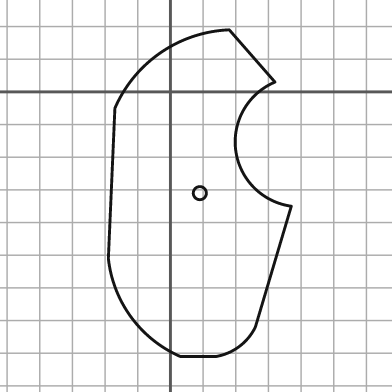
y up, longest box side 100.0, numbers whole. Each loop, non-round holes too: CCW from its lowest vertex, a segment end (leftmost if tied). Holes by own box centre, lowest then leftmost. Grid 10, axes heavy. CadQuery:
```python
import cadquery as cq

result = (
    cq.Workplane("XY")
    .moveTo(3.0, -81.0)
    .lineTo(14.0, -81.0)
    .threePointArc((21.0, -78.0), (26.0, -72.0))
    .lineTo(37.0, -35.0)
    .threePointArc((20.0, -18.0), (32.0, 3.0))
    .lineTo(18.0, 19.0)
    .threePointArc((-3.0, 12.0), (-17.0, -5.0))
    .lineTo(-19.0, -51.0)
    .threePointArc((-12.0, -69.0), (3.0, -81.0))
    .close()
    .moveTo(9.0, -31.0)
    .circle(2.0)
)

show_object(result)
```